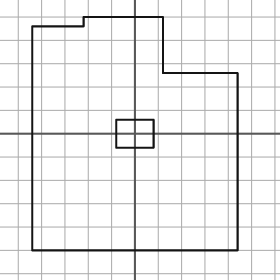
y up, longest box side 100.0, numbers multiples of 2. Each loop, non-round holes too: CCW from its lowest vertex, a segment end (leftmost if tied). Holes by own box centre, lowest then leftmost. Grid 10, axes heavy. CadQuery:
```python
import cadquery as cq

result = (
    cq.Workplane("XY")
    .moveTo(-44.0, -50.0)
    .lineTo(44.0, -50.0)
    .lineTo(44.0, 26.0)
    .lineTo(12.0, 26.0)
    .lineTo(12.0, 50.0)
    .lineTo(-22.0, 50.0)
    .lineTo(-22.0, 46.0)
    .lineTo(-44.0, 46.0)
    .close()
    .moveTo(-8.0, -6.0)
    .lineTo(8.0, -6.0)
    .lineTo(8.0, 6.0)
    .lineTo(-8.0, 6.0)
    .close()
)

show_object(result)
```